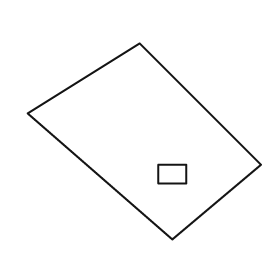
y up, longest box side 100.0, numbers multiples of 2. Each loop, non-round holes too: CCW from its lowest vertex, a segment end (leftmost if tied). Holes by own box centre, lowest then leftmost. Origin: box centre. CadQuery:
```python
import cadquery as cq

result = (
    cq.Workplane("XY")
    .moveTo(12.0, -42.0)
    .lineTo(50.0, -10.0)
    .lineTo(-2.0, 42.0)
    .lineTo(-50.0, 12.0)
    .close()
    .moveTo(6.0, -18.0)
    .lineTo(18.0, -18.0)
    .lineTo(18.0, -10.0)
    .lineTo(6.0, -10.0)
    .close()
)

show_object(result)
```